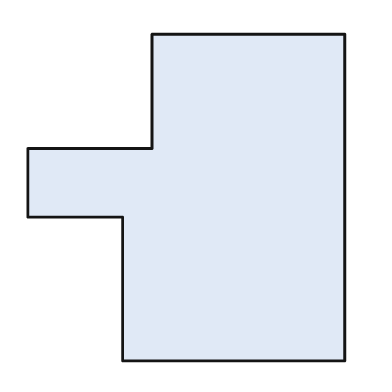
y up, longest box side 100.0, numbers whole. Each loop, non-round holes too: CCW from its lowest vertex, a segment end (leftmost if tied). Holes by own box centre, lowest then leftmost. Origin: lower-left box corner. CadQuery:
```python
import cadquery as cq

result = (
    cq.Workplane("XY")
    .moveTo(29.0, 0.0)
    .lineTo(97.0, 0.0)
    .lineTo(97.0, 100.0)
    .lineTo(38.0, 100.0)
    .lineTo(38.0, 65.0)
    .lineTo(0.0, 65.0)
    .lineTo(0.0, 44.0)
    .lineTo(29.0, 44.0)
    .close()
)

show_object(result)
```